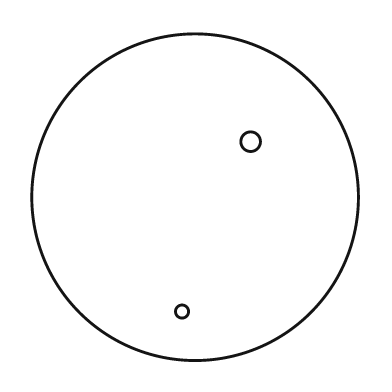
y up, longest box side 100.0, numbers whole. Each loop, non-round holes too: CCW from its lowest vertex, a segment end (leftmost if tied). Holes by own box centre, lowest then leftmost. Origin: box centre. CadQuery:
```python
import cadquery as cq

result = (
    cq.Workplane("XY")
    .moveTo(0.0, 0.0)
    .circle(50.0)
    .moveTo(-4.0, -35.0)
    .circle(2.0)
    .moveTo(17.0, 17.0)
    .circle(3.0)
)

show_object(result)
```